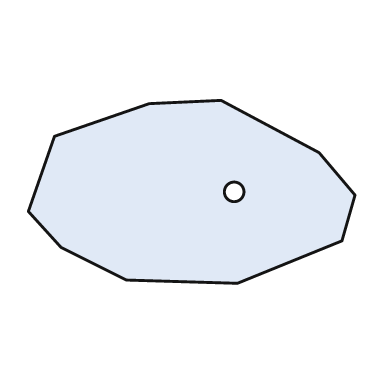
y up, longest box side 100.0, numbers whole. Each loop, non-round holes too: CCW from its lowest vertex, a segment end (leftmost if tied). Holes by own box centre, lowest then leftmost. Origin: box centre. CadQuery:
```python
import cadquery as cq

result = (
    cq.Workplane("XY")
    .moveTo(14.0, -28.0)
    .lineTo(46.0, -15.0)
    .lineTo(50.0, -1.0)
    .lineTo(39.0, 12.0)
    .lineTo(9.0, 28.0)
    .lineTo(-13.0, 27.0)
    .lineTo(-42.0, 17.0)
    .lineTo(-50.0, -6.0)
    .lineTo(-40.0, -17.0)
    .lineTo(-20.0, -27.0)
    .close()
    .moveTo(13.0, 0.0)
    .circle(3.0)
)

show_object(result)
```